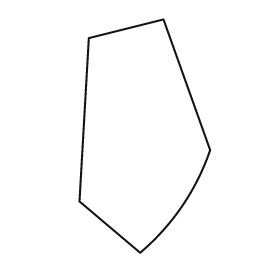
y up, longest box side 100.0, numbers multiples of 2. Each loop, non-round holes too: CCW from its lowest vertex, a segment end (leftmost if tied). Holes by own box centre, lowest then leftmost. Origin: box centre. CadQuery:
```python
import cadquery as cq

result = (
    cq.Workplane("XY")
    .moveTo(-2.0, -50.0)
    .threePointArc((16.0, -30.0), (28.0, -6.0))
    .lineTo(8.0, 50.0)
    .lineTo(-24.0, 42.0)
    .lineTo(-28.0, -28.0)
    .close()
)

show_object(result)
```